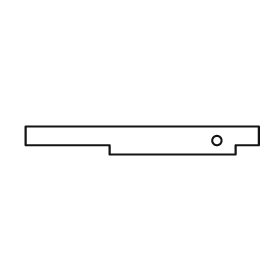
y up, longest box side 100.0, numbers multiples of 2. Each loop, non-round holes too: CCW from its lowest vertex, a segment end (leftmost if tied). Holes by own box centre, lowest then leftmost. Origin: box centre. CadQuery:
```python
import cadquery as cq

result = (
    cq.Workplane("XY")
    .moveTo(-14.0, -6.0)
    .lineTo(40.0, -6.0)
    .lineTo(40.0, -2.0)
    .lineTo(50.0, -2.0)
    .lineTo(50.0, 6.0)
    .lineTo(-50.0, 6.0)
    .lineTo(-50.0, -2.0)
    .lineTo(-14.0, -2.0)
    .close()
    .moveTo(32.0, 0.0)
    .circle(2.0)
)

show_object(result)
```